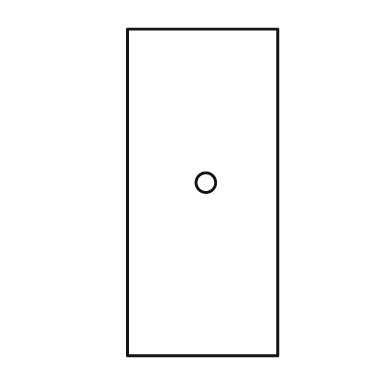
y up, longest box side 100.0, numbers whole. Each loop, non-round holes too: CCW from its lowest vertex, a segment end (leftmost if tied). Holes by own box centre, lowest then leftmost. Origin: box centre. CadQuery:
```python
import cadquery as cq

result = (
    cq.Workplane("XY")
    .moveTo(-23.0, -50.0)
    .lineTo(23.0, -50.0)
    .lineTo(23.0, 50.0)
    .lineTo(-23.0, 50.0)
    .close()
    .moveTo(1.0, 3.0)
    .circle(3.0)
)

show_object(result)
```